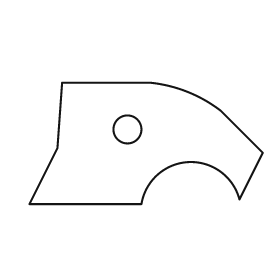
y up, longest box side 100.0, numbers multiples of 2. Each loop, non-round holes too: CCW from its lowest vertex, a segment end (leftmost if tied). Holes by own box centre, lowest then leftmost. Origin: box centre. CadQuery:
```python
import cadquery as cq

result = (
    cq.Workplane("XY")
    .moveTo(-50.0, -26.0)
    .lineTo(-2.0, -26.0)
    .threePointArc((18.0, -8.0), (40.0, -24.0))
    .lineTo(50.0, -4.0)
    .lineTo(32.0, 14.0)
    .threePointArc((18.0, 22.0), (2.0, 26.0))
    .lineTo(-36.0, 26.0)
    .lineTo(-38.0, -2.0)
    .close()
    .moveTo(-8.0, 6.0)
    .circle(6.0)
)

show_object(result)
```